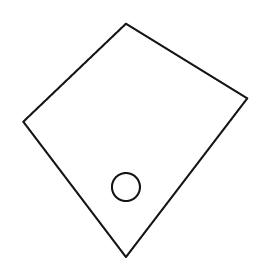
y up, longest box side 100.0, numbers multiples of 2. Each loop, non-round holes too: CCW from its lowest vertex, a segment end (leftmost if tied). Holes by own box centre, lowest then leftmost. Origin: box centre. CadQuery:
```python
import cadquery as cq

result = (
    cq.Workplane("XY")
    .moveTo(-4.0, -50.0)
    .lineTo(48.0, 18.0)
    .lineTo(-4.0, 50.0)
    .lineTo(-48.0, 8.0)
    .close()
    .moveTo(-4.0, -20.0)
    .circle(6.0)
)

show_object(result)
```